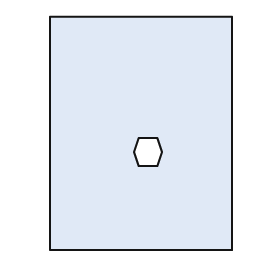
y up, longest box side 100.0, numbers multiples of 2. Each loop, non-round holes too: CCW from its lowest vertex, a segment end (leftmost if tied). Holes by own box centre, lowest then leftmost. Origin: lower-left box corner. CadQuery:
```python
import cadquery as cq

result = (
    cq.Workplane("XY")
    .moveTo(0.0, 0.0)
    .lineTo(78.0, 0.0)
    .lineTo(78.0, 100.0)
    .lineTo(0.0, 100.0)
    .close()
    .moveTo(38.0, 36.0)
    .lineTo(46.0, 36.0)
    .lineTo(48.0, 42.0)
    .lineTo(46.0, 48.0)
    .lineTo(38.0, 48.0)
    .lineTo(36.0, 42.0)
    .close()
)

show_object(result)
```